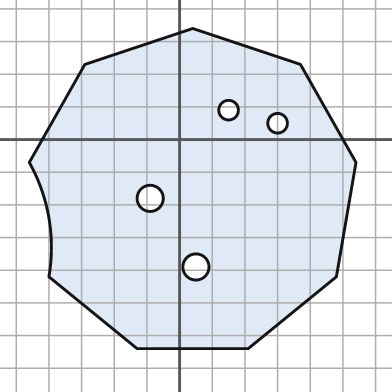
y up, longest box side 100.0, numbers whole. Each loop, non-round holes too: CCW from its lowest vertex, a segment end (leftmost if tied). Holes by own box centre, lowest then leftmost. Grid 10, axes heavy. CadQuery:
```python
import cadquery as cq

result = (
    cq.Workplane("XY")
    .moveTo(-13.0, -64.0)
    .lineTo(21.0, -64.0)
    .lineTo(48.0, -42.0)
    .lineTo(54.0, -7.0)
    .lineTo(37.0, 23.0)
    .lineTo(4.0, 34.0)
    .lineTo(-29.0, 23.0)
    .lineTo(-46.0, -7.0)
    .threePointArc((-40.0, -24.0), (-40.0, -42.0))
    .close()
    .moveTo(5.0, -39.0)
    .circle(4.0)
    .moveTo(-9.0, -18.0)
    .circle(4.0)
    .moveTo(30.0, 5.0)
    .circle(3.0)
    .moveTo(15.0, 9.0)
    .circle(3.0)
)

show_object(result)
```